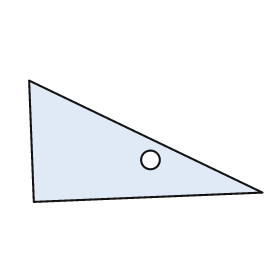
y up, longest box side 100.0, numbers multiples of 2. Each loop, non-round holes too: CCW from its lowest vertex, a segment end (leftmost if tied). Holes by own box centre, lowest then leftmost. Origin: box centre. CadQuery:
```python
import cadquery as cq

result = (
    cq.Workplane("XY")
    .moveTo(-48.0, -26.0)
    .lineTo(50.0, -22.0)
    .lineTo(-50.0, 26.0)
    .close()
    .moveTo(2.0, -8.0)
    .circle(4.0)
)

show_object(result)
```